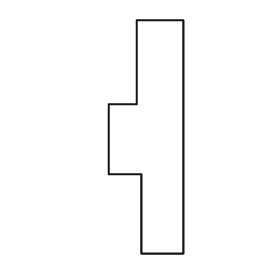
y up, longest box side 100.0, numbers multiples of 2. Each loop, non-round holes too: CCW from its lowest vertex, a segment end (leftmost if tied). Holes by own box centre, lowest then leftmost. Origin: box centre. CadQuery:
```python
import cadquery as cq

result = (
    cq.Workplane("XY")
    .moveTo(-2.0, -50.0)
    .lineTo(16.0, -50.0)
    .lineTo(16.0, 50.0)
    .lineTo(-4.0, 50.0)
    .lineTo(-4.0, 14.0)
    .lineTo(-16.0, 14.0)
    .lineTo(-16.0, -16.0)
    .lineTo(-2.0, -16.0)
    .close()
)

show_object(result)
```